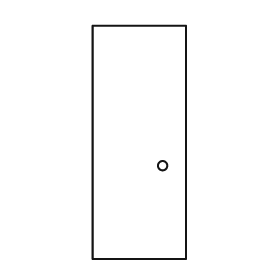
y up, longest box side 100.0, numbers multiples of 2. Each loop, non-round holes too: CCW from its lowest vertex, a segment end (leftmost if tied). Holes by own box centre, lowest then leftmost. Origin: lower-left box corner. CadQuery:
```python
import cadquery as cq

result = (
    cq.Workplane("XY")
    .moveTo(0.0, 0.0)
    .lineTo(40.0, 0.0)
    .lineTo(40.0, 100.0)
    .lineTo(0.0, 100.0)
    .close()
    .moveTo(30.0, 40.0)
    .circle(2.0)
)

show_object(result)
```